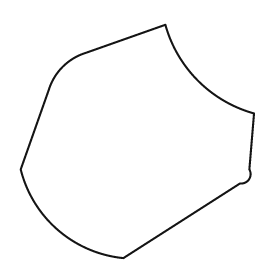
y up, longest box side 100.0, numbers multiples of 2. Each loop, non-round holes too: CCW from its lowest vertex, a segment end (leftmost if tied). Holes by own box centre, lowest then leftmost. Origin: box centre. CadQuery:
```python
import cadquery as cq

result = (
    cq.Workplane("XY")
    .moveTo(-6.0, -50.0)
    .lineTo(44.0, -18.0)
    .threePointArc((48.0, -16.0), (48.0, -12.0))
    .lineTo(50.0, 12.0)
    .threePointArc((26.0, 26.0), (12.0, 50.0))
    .lineTo(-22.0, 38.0)
    .threePointArc((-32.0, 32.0), (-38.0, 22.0))
    .lineTo(-50.0, -12.0)
    .threePointArc((-34.0, -38.0), (-6.0, -50.0))
    .close()
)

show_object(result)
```